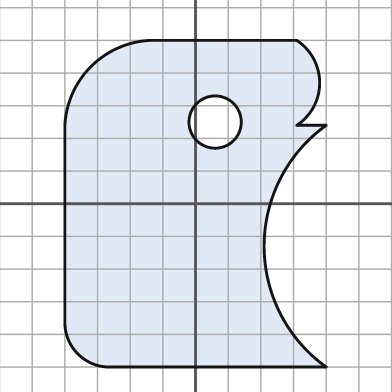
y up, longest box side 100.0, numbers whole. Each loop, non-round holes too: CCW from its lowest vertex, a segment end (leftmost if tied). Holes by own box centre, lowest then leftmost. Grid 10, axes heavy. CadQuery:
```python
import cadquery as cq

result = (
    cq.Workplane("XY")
    .moveTo(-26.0, -50.0)
    .lineTo(40.0, -50.0)
    .threePointArc((21.0, -13.0), (40.0, 24.0))
    .lineTo(31.0, 24.0)
    .threePointArc((38.0, 37.0), (31.0, 50.0))
    .lineTo(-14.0, 50.0)
    .threePointArc((-32.0, 42.0), (-40.0, 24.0))
    .lineTo(-40.0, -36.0)
    .threePointArc((-36.0, -46.0), (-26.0, -50.0))
    .close()
    .moveTo(6.0, 25.0)
    .circle(8.0)
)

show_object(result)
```